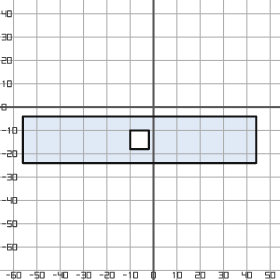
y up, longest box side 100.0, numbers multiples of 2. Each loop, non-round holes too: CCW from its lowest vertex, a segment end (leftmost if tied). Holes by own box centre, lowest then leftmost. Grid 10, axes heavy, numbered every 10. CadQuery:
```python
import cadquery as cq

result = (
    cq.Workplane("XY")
    .moveTo(-56.0, -24.0)
    .lineTo(44.0, -24.0)
    .lineTo(44.0, -4.0)
    .lineTo(-56.0, -4.0)
    .close()
    .moveTo(-10.0, -18.0)
    .lineTo(-2.0, -18.0)
    .lineTo(-2.0, -10.0)
    .lineTo(-10.0, -10.0)
    .close()
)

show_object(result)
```